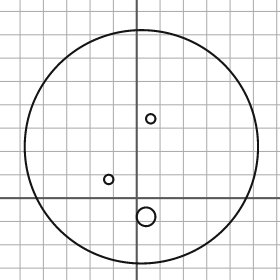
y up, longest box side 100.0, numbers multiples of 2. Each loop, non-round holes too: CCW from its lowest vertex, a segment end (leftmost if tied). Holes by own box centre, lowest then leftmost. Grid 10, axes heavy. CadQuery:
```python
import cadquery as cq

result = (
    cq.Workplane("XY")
    .moveTo(2.0, 22.0)
    .circle(50.0)
    .moveTo(4.0, -8.0)
    .circle(4.0)
    .moveTo(-12.0, 8.0)
    .circle(2.0)
    .moveTo(6.0, 34.0)
    .circle(2.0)
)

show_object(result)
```